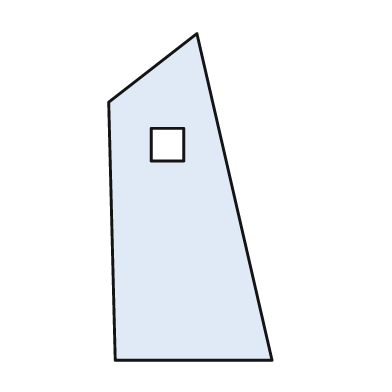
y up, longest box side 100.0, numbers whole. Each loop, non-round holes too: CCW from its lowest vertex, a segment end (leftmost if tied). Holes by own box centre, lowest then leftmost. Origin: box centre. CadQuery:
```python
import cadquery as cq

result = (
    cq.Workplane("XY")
    .moveTo(-23.0, -50.0)
    .lineTo(25.0, -50.0)
    .lineTo(2.0, 50.0)
    .lineTo(-25.0, 29.0)
    .close()
    .moveTo(-12.0, 11.0)
    .lineTo(-2.0, 11.0)
    .lineTo(-2.0, 21.0)
    .lineTo(-12.0, 21.0)
    .close()
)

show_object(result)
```